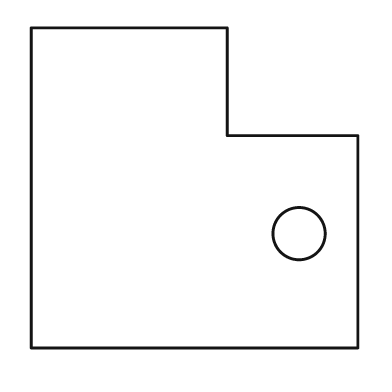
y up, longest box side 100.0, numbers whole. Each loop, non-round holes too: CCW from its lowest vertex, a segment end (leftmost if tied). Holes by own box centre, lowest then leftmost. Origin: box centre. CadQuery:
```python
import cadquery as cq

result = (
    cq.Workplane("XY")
    .moveTo(-50.0, -49.0)
    .lineTo(50.0, -49.0)
    .lineTo(50.0, 16.0)
    .lineTo(10.0, 16.0)
    .lineTo(10.0, 49.0)
    .lineTo(-50.0, 49.0)
    .close()
    .moveTo(32.0, -14.0)
    .circle(8.0)
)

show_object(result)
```